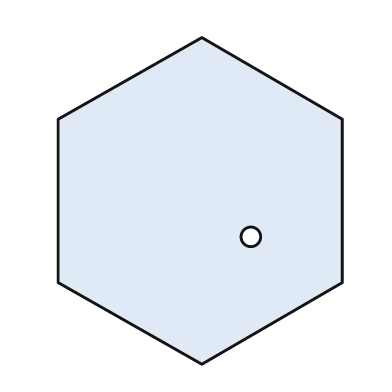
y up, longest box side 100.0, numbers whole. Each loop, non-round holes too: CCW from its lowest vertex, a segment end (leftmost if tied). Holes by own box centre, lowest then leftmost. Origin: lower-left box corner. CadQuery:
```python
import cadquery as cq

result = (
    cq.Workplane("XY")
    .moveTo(44.0, 0.0)
    .lineTo(87.0, 25.0)
    .lineTo(87.0, 75.0)
    .lineTo(44.0, 100.0)
    .lineTo(0.0, 75.0)
    .lineTo(0.0, 25.0)
    .close()
    .moveTo(59.0, 39.0)
    .circle(3.0)
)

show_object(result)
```